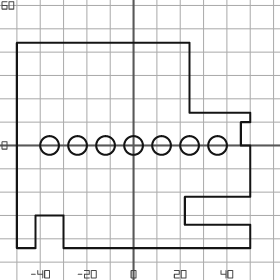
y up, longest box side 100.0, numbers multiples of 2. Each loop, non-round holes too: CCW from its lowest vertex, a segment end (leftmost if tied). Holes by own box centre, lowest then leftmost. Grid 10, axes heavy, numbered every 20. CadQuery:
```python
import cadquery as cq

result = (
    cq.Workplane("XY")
    .moveTo(-50.0, -44.0)
    .lineTo(-42.0, -44.0)
    .lineTo(-42.0, -30.0)
    .lineTo(-30.0, -30.0)
    .lineTo(-30.0, -44.0)
    .lineTo(50.0, -44.0)
    .lineTo(50.0, -34.0)
    .lineTo(22.0, -34.0)
    .lineTo(22.0, -22.0)
    .lineTo(50.0, -22.0)
    .lineTo(50.0, 0.0)
    .lineTo(46.0, 0.0)
    .lineTo(46.0, 10.0)
    .lineTo(50.0, 10.0)
    .lineTo(50.0, 14.0)
    .lineTo(24.0, 14.0)
    .lineTo(24.0, 44.0)
    .lineTo(-50.0, 44.0)
    .close()
    .moveTo(-36.0, 0.0)
    .circle(4.0)
    .moveTo(-24.0, 0.0)
    .circle(4.0)
    .moveTo(-12.0, 0.0)
    .circle(4.0)
    .moveTo(0.0, 0.0)
    .circle(4.0)
    .moveTo(12.0, 0.0)
    .circle(4.0)
    .moveTo(24.0, 0.0)
    .circle(4.0)
    .moveTo(36.0, 0.0)
    .circle(4.0)
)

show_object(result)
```